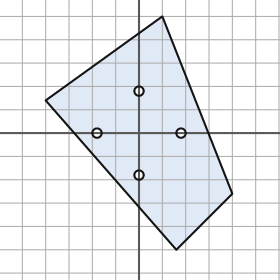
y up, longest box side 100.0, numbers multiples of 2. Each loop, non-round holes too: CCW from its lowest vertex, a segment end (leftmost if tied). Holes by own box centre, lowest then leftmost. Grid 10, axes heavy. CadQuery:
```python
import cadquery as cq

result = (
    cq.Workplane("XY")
    .moveTo(16.0, -50.0)
    .lineTo(40.0, -26.0)
    .lineTo(10.0, 50.0)
    .lineTo(-40.0, 14.0)
    .close()
    .moveTo(0.0, -18.0)
    .circle(2.0)
    .moveTo(-18.0, 0.0)
    .circle(2.0)
    .moveTo(18.0, 0.0)
    .circle(2.0)
    .moveTo(0.0, 18.0)
    .circle(2.0)
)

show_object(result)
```